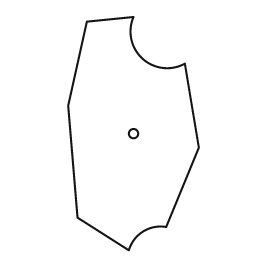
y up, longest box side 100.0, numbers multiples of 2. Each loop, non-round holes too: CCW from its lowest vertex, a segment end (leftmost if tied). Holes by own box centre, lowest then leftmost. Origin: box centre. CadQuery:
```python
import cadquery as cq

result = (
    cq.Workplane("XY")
    .moveTo(-2.0, -50.0)
    .threePointArc((4.0, -42.0), (14.0, -40.0))
    .lineTo(28.0, -6.0)
    .lineTo(22.0, 30.0)
    .threePointArc((4.0, 32.0), (0.0, 50.0))
    .lineTo(-20.0, 48.0)
    .lineTo(-28.0, 12.0)
    .lineTo(-24.0, -36.0)
    .close()
    .moveTo(0.0, 0.0)
    .circle(2.0)
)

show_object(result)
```